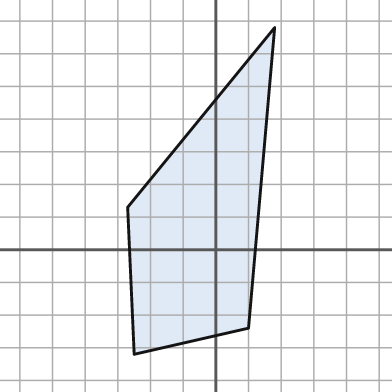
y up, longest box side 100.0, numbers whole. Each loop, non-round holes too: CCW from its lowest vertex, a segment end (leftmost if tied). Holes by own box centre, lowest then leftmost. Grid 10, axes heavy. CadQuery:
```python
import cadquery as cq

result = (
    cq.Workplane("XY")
    .moveTo(-25.0, -32.0)
    .lineTo(10.0, -24.0)
    .lineTo(18.0, 68.0)
    .lineTo(-27.0, 13.0)
    .close()
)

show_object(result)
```